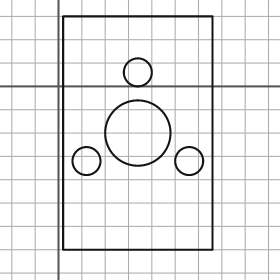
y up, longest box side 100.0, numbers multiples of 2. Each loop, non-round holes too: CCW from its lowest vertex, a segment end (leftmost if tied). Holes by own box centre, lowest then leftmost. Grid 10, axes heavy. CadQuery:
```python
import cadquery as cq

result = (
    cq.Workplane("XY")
    .moveTo(2.0, -70.0)
    .lineTo(66.0, -70.0)
    .lineTo(66.0, 30.0)
    .lineTo(2.0, 30.0)
    .close()
    .moveTo(12.0, -32.0)
    .circle(6.0)
    .moveTo(56.0, -32.0)
    .circle(6.0)
    .moveTo(34.0, -20.0)
    .circle(14.0)
    .moveTo(34.0, 6.0)
    .circle(6.0)
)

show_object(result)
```